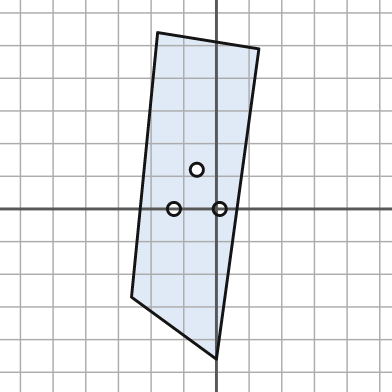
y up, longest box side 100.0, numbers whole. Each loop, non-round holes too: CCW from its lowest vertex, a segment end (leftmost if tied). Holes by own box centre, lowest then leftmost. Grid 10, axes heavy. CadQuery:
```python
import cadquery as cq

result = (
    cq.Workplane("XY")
    .moveTo(0.0, -46.0)
    .lineTo(13.0, 49.0)
    .lineTo(-18.0, 54.0)
    .lineTo(-26.0, -27.0)
    .close()
    .moveTo(-13.0, 0.0)
    .circle(2.0)
    .moveTo(1.0, 0.0)
    .circle(2.0)
    .moveTo(-6.0, 12.0)
    .circle(2.0)
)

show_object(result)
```